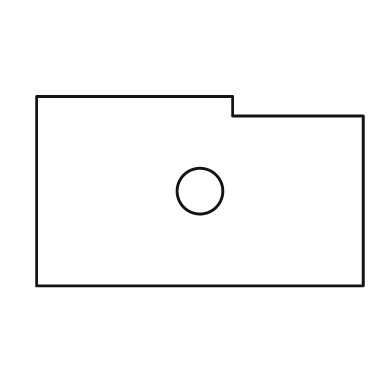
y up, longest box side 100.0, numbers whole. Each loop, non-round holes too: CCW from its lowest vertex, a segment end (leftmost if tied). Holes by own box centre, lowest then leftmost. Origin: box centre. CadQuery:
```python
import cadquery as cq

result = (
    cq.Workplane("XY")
    .moveTo(-50.0, -29.0)
    .lineTo(50.0, -29.0)
    .lineTo(50.0, 23.0)
    .lineTo(10.0, 23.0)
    .lineTo(10.0, 29.0)
    .lineTo(-50.0, 29.0)
    .close()
    .moveTo(0.0, 0.0)
    .circle(7.0)
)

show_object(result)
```